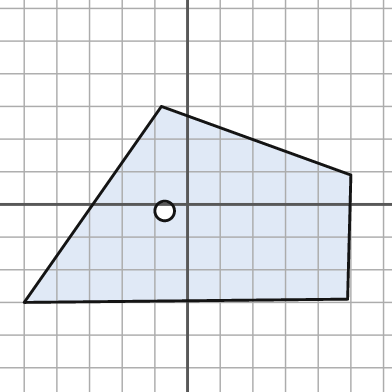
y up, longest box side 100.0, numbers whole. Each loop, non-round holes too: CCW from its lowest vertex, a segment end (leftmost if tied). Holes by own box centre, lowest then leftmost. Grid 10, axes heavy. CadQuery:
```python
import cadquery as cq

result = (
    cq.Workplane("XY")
    .moveTo(-50.0, -30.0)
    .lineTo(49.0, -29.0)
    .lineTo(50.0, 9.0)
    .lineTo(-8.0, 30.0)
    .close()
    .moveTo(-7.0, -2.0)
    .circle(3.0)
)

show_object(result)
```